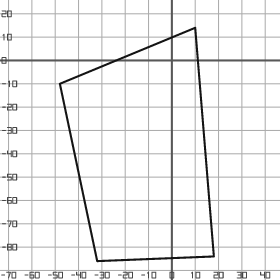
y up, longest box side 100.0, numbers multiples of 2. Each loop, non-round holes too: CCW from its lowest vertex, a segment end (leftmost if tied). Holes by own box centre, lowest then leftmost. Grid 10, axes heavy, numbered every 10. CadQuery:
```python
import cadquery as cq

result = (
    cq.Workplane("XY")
    .moveTo(-32.0, -86.0)
    .lineTo(18.0, -84.0)
    .lineTo(10.0, 14.0)
    .lineTo(-48.0, -10.0)
    .close()
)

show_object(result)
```